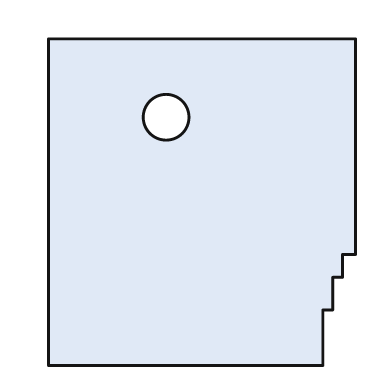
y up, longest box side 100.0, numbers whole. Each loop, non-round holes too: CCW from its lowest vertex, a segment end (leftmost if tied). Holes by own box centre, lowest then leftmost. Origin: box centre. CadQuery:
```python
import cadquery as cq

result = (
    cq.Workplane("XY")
    .moveTo(-47.0, -50.0)
    .lineTo(37.0, -50.0)
    .lineTo(37.0, -33.0)
    .lineTo(40.0, -33.0)
    .lineTo(40.0, -23.0)
    .lineTo(43.0, -23.0)
    .lineTo(43.0, -16.0)
    .lineTo(47.0, -16.0)
    .lineTo(47.0, 50.0)
    .lineTo(-47.0, 50.0)
    .close()
    .moveTo(-11.0, 26.0)
    .circle(7.0)
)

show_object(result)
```